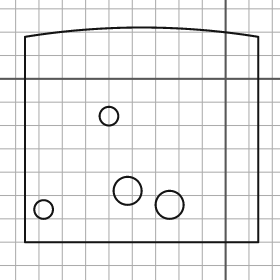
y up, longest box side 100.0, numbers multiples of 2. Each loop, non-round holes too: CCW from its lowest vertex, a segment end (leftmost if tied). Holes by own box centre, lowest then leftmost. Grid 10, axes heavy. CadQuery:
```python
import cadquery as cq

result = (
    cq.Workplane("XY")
    .moveTo(-86.0, -70.0)
    .lineTo(14.0, -70.0)
    .lineTo(14.0, 18.0)
    .threePointArc((-36.0, 22.0), (-86.0, 18.0))
    .close()
    .moveTo(-78.0, -56.0)
    .circle(4.0)
    .moveTo(-24.0, -54.0)
    .circle(6.0)
    .moveTo(-42.0, -48.0)
    .circle(6.0)
    .moveTo(-50.0, -16.0)
    .circle(4.0)
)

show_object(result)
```